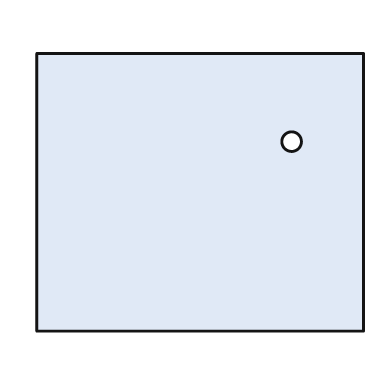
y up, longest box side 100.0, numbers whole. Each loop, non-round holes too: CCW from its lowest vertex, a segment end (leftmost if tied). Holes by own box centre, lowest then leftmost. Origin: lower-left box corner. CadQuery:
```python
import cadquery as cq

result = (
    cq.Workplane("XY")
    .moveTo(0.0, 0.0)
    .lineTo(100.0, 0.0)
    .lineTo(100.0, 85.0)
    .lineTo(0.0, 85.0)
    .close()
    .moveTo(78.0, 58.0)
    .circle(3.0)
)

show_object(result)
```